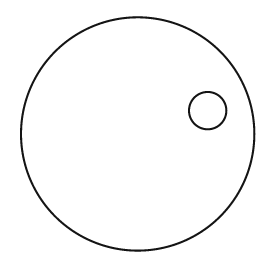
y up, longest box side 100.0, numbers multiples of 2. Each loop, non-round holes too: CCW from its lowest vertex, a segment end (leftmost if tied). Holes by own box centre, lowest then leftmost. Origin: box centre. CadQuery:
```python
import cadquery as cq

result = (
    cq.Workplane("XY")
    .moveTo(0.0, 0.0)
    .circle(50.0)
    .moveTo(30.0, 10.0)
    .circle(8.0)
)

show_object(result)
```